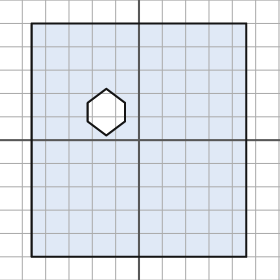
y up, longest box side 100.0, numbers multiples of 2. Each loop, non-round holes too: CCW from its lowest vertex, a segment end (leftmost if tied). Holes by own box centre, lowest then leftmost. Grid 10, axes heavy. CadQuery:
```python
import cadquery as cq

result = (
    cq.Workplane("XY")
    .moveTo(-46.0, -50.0)
    .lineTo(46.0, -50.0)
    .lineTo(46.0, 50.0)
    .lineTo(-46.0, 50.0)
    .close()
    .moveTo(-14.0, 2.0)
    .lineTo(-6.0, 8.0)
    .lineTo(-6.0, 16.0)
    .lineTo(-14.0, 22.0)
    .lineTo(-22.0, 16.0)
    .lineTo(-22.0, 8.0)
    .close()
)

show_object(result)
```